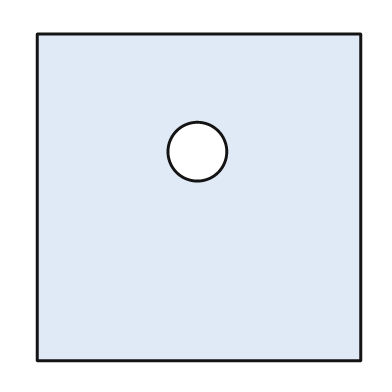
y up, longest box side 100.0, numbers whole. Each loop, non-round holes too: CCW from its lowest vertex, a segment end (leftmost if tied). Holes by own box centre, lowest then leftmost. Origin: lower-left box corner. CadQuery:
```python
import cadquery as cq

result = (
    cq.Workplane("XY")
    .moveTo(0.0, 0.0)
    .lineTo(99.0, 0.0)
    .lineTo(99.0, 100.0)
    .lineTo(0.0, 100.0)
    .close()
    .moveTo(49.0, 64.0)
    .circle(9.0)
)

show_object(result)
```